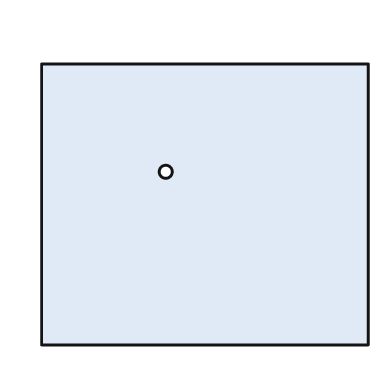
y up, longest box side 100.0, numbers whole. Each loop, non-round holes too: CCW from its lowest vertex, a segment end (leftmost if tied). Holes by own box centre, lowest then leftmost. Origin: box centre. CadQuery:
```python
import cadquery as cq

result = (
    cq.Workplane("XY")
    .moveTo(-50.0, -43.0)
    .lineTo(50.0, -43.0)
    .lineTo(50.0, 43.0)
    .lineTo(-50.0, 43.0)
    .close()
    .moveTo(-12.0, 10.0)
    .circle(2.0)
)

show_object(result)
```